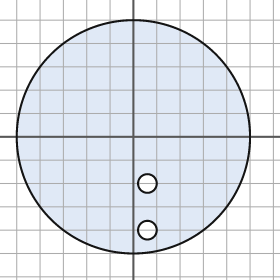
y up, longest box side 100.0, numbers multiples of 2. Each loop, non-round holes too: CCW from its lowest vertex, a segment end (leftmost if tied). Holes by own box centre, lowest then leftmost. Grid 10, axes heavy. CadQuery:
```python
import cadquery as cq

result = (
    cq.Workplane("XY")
    .moveTo(0.0, 0.0)
    .circle(50.0)
    .moveTo(6.0, -40.0)
    .circle(4.0)
    .moveTo(6.0, -20.0)
    .circle(4.0)
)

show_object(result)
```